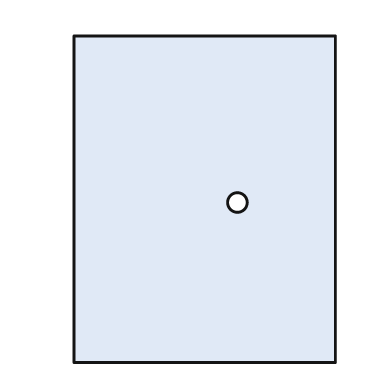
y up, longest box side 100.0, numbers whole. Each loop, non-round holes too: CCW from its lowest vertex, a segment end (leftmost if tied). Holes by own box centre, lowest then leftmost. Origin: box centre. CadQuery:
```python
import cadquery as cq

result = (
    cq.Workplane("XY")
    .moveTo(-40.0, -50.0)
    .lineTo(40.0, -50.0)
    .lineTo(40.0, 50.0)
    .lineTo(-40.0, 50.0)
    .close()
    .moveTo(10.0, -1.0)
    .circle(3.0)
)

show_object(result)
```